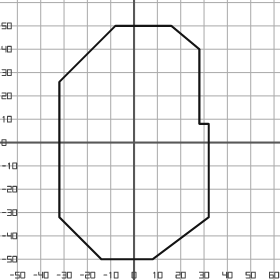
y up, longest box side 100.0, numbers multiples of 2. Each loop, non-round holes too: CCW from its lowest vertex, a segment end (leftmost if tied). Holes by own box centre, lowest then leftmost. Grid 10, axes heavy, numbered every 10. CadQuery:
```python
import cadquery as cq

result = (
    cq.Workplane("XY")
    .moveTo(-14.0, -50.0)
    .lineTo(8.0, -50.0)
    .lineTo(32.0, -32.0)
    .lineTo(32.0, 8.0)
    .lineTo(28.0, 8.0)
    .lineTo(28.0, 40.0)
    .lineTo(16.0, 50.0)
    .lineTo(-8.0, 50.0)
    .lineTo(-32.0, 26.0)
    .lineTo(-32.0, -32.0)
    .close()
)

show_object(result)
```